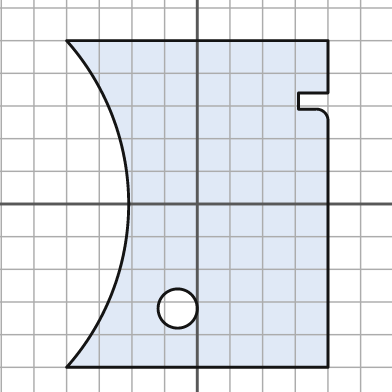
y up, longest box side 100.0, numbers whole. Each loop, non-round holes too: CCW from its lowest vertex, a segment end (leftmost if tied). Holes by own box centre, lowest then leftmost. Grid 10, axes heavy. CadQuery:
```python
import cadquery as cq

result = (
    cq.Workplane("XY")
    .moveTo(-40.0, -50.0)
    .lineTo(40.0, -50.0)
    .lineTo(40.0, 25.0)
    .threePointArc((39.0, 28.0), (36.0, 29.0))
    .lineTo(31.0, 29.0)
    .lineTo(31.0, 34.0)
    .lineTo(40.0, 34.0)
    .lineTo(40.0, 50.0)
    .lineTo(-40.0, 50.0)
    .threePointArc((-21.0, 0.0), (-40.0, -50.0))
    .close()
    .moveTo(-6.0, -32.0)
    .circle(6.0)
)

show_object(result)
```